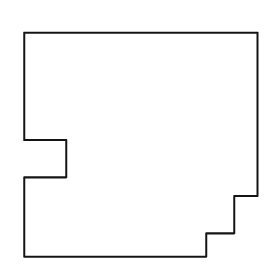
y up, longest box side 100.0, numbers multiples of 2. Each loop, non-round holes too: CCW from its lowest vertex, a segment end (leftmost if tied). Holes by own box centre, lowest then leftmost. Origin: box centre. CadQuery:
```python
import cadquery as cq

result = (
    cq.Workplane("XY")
    .moveTo(-50.0, -48.0)
    .lineTo(28.0, -48.0)
    .lineTo(28.0, -38.0)
    .lineTo(40.0, -38.0)
    .lineTo(40.0, -22.0)
    .lineTo(50.0, -22.0)
    .lineTo(50.0, 48.0)
    .lineTo(-50.0, 48.0)
    .lineTo(-50.0, 2.0)
    .lineTo(-32.0, 2.0)
    .lineTo(-32.0, -14.0)
    .lineTo(-50.0, -14.0)
    .close()
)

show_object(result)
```